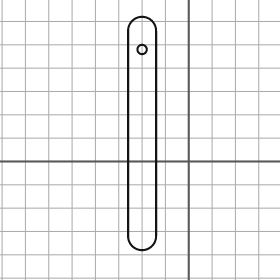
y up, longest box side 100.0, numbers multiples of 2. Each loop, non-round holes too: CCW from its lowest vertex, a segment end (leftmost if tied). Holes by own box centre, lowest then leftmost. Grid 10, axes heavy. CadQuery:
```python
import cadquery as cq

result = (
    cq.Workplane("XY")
    .moveTo(-26.0, -32.0)
    .threePointArc((-20.0, -38.0), (-14.0, -32.0))
    .lineTo(-14.0, 56.0)
    .threePointArc((-20.0, 62.0), (-26.0, 56.0))
    .close()
    .moveTo(-20.0, 48.0)
    .circle(2.0)
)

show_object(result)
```